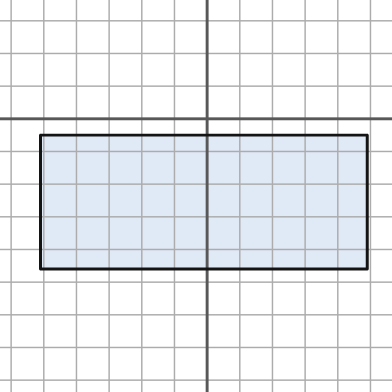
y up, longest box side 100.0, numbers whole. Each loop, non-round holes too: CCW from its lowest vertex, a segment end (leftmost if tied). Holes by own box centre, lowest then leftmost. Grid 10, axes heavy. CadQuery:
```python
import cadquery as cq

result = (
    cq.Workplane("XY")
    .moveTo(-51.0, -46.0)
    .lineTo(49.0, -46.0)
    .lineTo(49.0, -5.0)
    .lineTo(-51.0, -5.0)
    .close()
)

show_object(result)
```